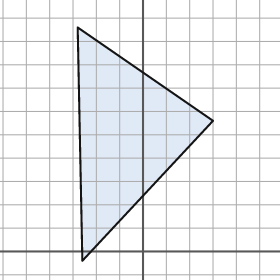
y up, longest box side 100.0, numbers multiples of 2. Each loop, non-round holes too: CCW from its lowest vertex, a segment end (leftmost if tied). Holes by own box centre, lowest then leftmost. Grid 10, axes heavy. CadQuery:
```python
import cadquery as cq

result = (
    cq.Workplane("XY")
    .moveTo(-26.0, -4.0)
    .lineTo(30.0, 56.0)
    .lineTo(-28.0, 96.0)
    .close()
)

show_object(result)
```